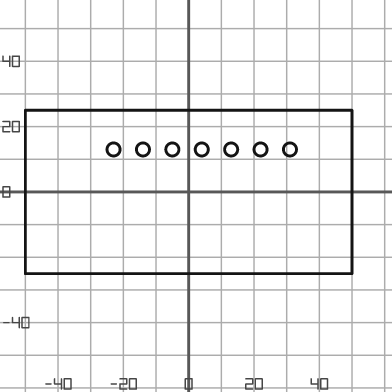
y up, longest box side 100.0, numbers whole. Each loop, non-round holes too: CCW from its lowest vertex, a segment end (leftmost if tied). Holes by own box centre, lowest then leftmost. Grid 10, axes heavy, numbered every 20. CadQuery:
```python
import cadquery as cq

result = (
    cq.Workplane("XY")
    .moveTo(-50.0, -25.0)
    .lineTo(50.0, -25.0)
    .lineTo(50.0, 25.0)
    .lineTo(-50.0, 25.0)
    .close()
    .moveTo(-23.0, 13.0)
    .circle(2.0)
    .moveTo(-14.0, 13.0)
    .circle(2.0)
    .moveTo(-5.0, 13.0)
    .circle(2.0)
    .moveTo(4.0, 13.0)
    .circle(2.0)
    .moveTo(13.0, 13.0)
    .circle(2.0)
    .moveTo(22.0, 13.0)
    .circle(2.0)
    .moveTo(31.0, 13.0)
    .circle(2.0)
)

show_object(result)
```